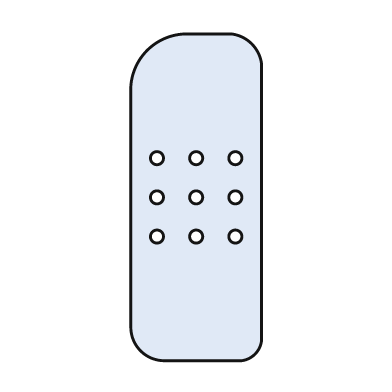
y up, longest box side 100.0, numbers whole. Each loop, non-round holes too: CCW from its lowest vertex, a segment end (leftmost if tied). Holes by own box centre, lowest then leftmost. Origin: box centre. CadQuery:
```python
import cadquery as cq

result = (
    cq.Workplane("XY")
    .moveTo(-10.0, -50.0)
    .lineTo(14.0, -50.0)
    .threePointArc((18.0, -48.0), (20.0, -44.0))
    .lineTo(20.0, 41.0)
    .threePointArc((17.0, 47.0), (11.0, 50.0))
    .lineTo(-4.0, 50.0)
    .threePointArc((-15.0, 45.0), (-20.0, 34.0))
    .lineTo(-20.0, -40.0)
    .threePointArc((-17.0, -47.0), (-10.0, -50.0))
    .close()
    .moveTo(-12.0, -12.0)
    .circle(2.0)
    .moveTo(0.0, -12.0)
    .circle(2.0)
    .moveTo(12.0, -12.0)
    .circle(2.0)
    .moveTo(-12.0, 0.0)
    .circle(2.0)
    .moveTo(0.0, 0.0)
    .circle(2.0)
    .moveTo(12.0, 0.0)
    .circle(2.0)
    .moveTo(-12.0, 12.0)
    .circle(2.0)
    .moveTo(0.0, 12.0)
    .circle(2.0)
    .moveTo(12.0, 12.0)
    .circle(2.0)
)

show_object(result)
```